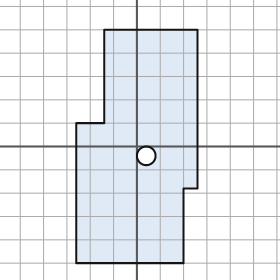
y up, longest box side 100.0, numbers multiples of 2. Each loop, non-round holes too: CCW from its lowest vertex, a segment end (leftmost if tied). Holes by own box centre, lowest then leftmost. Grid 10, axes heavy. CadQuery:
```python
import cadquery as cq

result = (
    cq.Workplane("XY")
    .moveTo(-26.0, -50.0)
    .lineTo(20.0, -50.0)
    .lineTo(20.0, -18.0)
    .lineTo(26.0, -18.0)
    .lineTo(26.0, 50.0)
    .lineTo(-14.0, 50.0)
    .lineTo(-14.0, 10.0)
    .lineTo(-26.0, 10.0)
    .close()
    .moveTo(4.0, -4.0)
    .circle(4.0)
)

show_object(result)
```